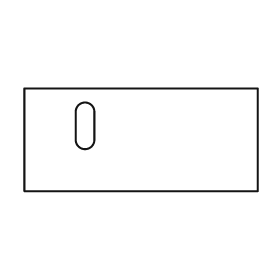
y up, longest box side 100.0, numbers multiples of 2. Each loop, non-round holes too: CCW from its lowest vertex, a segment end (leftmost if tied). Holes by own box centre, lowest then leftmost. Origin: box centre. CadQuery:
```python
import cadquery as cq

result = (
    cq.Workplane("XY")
    .moveTo(-50.0, -22.0)
    .lineTo(50.0, -22.0)
    .lineTo(50.0, 22.0)
    .lineTo(-50.0, 22.0)
    .close()
    .moveTo(-28.0, 0.0)
    .threePointArc((-24.0, -4.0), (-20.0, 0.0))
    .lineTo(-20.0, 12.0)
    .threePointArc((-24.0, 16.0), (-28.0, 12.0))
    .close()
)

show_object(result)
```